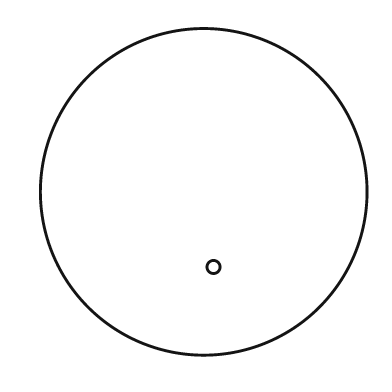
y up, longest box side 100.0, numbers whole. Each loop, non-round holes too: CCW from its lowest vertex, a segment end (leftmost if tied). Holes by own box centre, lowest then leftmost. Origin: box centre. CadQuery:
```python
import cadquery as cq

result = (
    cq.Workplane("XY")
    .moveTo(0.0, 0.0)
    .circle(50.0)
    .moveTo(3.0, -23.0)
    .circle(2.0)
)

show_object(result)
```